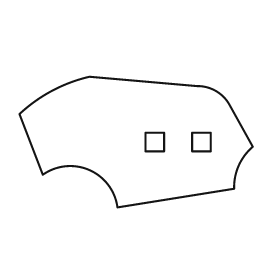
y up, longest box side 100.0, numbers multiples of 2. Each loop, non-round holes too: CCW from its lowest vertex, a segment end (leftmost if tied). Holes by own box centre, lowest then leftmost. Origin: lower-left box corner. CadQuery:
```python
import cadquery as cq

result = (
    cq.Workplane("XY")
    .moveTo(42.0, 0.0)
    .lineTo(92.0, 8.0)
    .threePointArc((94.0, 18.0), (100.0, 26.0))
    .lineTo(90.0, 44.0)
    .threePointArc((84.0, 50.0), (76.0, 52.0))
    .lineTo(30.0, 56.0)
    .threePointArc((14.0, 50.0), (0.0, 40.0))
    .lineTo(10.0, 14.0)
    .threePointArc((30.0, 16.0), (42.0, 0.0))
    .close()
    .moveTo(54.0, 24.0)
    .lineTo(62.0, 24.0)
    .lineTo(62.0, 32.0)
    .lineTo(54.0, 32.0)
    .close()
    .moveTo(74.0, 24.0)
    .lineTo(82.0, 24.0)
    .lineTo(82.0, 32.0)
    .lineTo(74.0, 32.0)
    .close()
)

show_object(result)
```